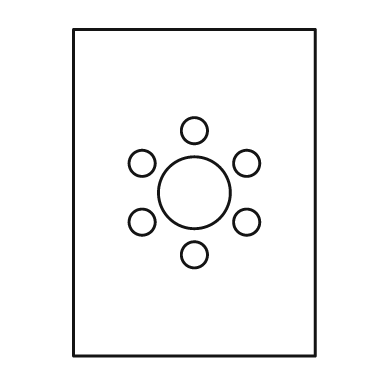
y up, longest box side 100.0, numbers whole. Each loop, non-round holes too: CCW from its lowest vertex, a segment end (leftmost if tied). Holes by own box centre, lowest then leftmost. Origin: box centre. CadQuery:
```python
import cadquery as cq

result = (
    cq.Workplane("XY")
    .moveTo(-37.0, -50.0)
    .lineTo(37.0, -50.0)
    .lineTo(37.0, 50.0)
    .lineTo(-37.0, 50.0)
    .close()
    .moveTo(0.0, -19.0)
    .circle(4.0)
    .moveTo(-16.0, -9.0)
    .circle(4.0)
    .moveTo(16.0, -9.0)
    .circle(4.0)
    .moveTo(0.0, 0.0)
    .circle(11.0)
    .moveTo(-16.0, 9.0)
    .circle(4.0)
    .moveTo(16.0, 9.0)
    .circle(4.0)
    .moveTo(0.0, 19.0)
    .circle(4.0)
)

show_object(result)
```